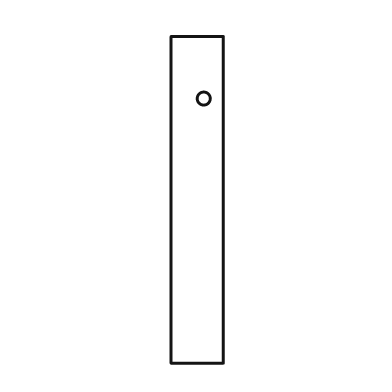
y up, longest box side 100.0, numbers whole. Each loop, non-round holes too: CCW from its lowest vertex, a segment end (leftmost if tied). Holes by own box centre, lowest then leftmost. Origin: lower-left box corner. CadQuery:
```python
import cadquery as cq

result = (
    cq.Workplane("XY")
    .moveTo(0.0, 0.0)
    .lineTo(16.0, 0.0)
    .lineTo(16.0, 100.0)
    .lineTo(0.0, 100.0)
    .close()
    .moveTo(10.0, 81.0)
    .circle(2.0)
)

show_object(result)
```